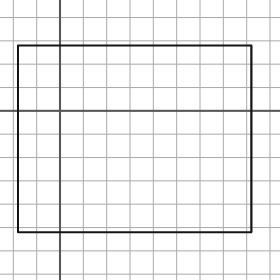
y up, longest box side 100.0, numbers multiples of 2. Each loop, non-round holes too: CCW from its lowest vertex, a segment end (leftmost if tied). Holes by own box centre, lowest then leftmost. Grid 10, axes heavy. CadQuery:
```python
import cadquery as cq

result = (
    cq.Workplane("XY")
    .moveTo(-18.0, -52.0)
    .lineTo(82.0, -52.0)
    .lineTo(82.0, 28.0)
    .lineTo(-18.0, 28.0)
    .close()
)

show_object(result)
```